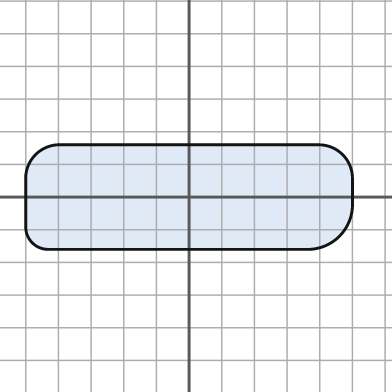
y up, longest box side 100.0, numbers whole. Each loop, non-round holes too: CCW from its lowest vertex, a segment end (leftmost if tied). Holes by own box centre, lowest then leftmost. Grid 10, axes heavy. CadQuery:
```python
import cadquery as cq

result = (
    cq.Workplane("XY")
    .moveTo(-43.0, -16.0)
    .lineTo(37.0, -16.0)
    .threePointArc((46.0, -12.0), (50.0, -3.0))
    .lineTo(50.0, 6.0)
    .threePointArc((47.0, 13.0), (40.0, 16.0))
    .lineTo(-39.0, 16.0)
    .threePointArc((-47.0, 13.0), (-50.0, 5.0))
    .lineTo(-50.0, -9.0)
    .threePointArc((-48.0, -14.0), (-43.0, -16.0))
    .close()
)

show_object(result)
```